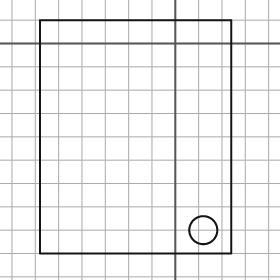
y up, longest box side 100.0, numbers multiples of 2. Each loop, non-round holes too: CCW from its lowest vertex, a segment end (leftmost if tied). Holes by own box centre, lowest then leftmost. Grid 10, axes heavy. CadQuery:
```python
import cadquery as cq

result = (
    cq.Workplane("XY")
    .moveTo(-58.0, -90.0)
    .lineTo(24.0, -90.0)
    .lineTo(24.0, 10.0)
    .lineTo(-58.0, 10.0)
    .close()
    .moveTo(12.0, -80.0)
    .circle(6.0)
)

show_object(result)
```